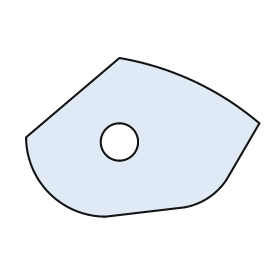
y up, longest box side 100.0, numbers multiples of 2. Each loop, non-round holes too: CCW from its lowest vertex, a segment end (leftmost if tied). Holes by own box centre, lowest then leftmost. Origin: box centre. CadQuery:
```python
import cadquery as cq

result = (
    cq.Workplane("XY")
    .moveTo(-16.0, -34.0)
    .lineTo(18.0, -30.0)
    .threePointArc((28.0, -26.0), (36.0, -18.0))
    .lineTo(50.0, 6.0)
    .threePointArc((22.0, 24.0), (-10.0, 34.0))
    .lineTo(-50.0, 0.0)
    .threePointArc((-40.0, -24.0), (-16.0, -34.0))
    .close()
    .moveTo(-10.0, -2.0)
    .circle(8.0)
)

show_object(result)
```